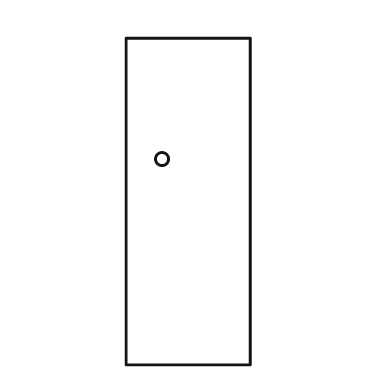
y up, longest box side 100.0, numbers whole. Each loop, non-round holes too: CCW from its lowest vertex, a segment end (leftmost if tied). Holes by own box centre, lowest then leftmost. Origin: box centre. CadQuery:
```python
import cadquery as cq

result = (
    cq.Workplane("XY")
    .moveTo(-19.0, -50.0)
    .lineTo(19.0, -50.0)
    .lineTo(19.0, 50.0)
    .lineTo(-19.0, 50.0)
    .close()
    .moveTo(-8.0, 13.0)
    .circle(2.0)
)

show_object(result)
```